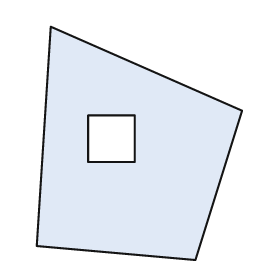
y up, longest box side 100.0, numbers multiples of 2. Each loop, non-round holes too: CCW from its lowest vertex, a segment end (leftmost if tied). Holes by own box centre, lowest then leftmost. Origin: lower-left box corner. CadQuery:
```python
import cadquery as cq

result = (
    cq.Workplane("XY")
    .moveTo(68.0, 0.0)
    .lineTo(88.0, 64.0)
    .lineTo(6.0, 100.0)
    .lineTo(0.0, 6.0)
    .close()
    .moveTo(22.0, 42.0)
    .lineTo(42.0, 42.0)
    .lineTo(42.0, 62.0)
    .lineTo(22.0, 62.0)
    .close()
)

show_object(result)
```